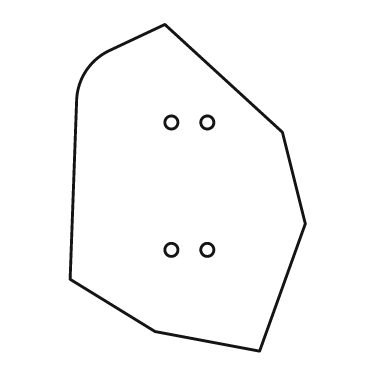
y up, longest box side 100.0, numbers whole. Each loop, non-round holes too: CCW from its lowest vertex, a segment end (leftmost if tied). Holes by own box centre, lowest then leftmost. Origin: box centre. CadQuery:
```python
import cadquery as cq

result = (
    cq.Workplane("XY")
    .moveTo(22.0, -50.0)
    .lineTo(36.0, -11.0)
    .lineTo(29.0, 17.0)
    .lineTo(-7.0, 50.0)
    .lineTo(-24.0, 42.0)
    .threePointArc((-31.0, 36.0), (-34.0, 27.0))
    .lineTo(-36.0, -28.0)
    .lineTo(-10.0, -44.0)
    .close()
    .moveTo(-5.0, -19.0)
    .circle(2.0)
    .moveTo(6.0, -19.0)
    .circle(2.0)
    .moveTo(-5.0, 20.0)
    .circle(2.0)
    .moveTo(6.0, 20.0)
    .circle(2.0)
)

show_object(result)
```